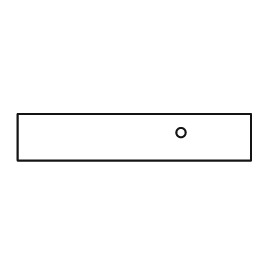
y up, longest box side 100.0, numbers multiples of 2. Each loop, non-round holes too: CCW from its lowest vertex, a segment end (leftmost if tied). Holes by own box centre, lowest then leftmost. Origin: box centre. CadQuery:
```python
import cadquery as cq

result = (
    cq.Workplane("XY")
    .moveTo(-50.0, -10.0)
    .lineTo(50.0, -10.0)
    .lineTo(50.0, 10.0)
    .lineTo(-50.0, 10.0)
    .close()
    .moveTo(20.0, 2.0)
    .circle(2.0)
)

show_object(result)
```